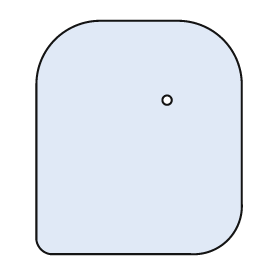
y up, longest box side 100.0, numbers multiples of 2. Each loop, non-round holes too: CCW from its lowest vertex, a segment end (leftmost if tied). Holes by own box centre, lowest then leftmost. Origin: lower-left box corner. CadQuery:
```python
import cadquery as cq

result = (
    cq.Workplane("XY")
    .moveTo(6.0, 0.0)
    .lineTo(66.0, 0.0)
    .threePointArc((82.0, 6.0), (88.0, 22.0))
    .lineTo(88.0, 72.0)
    .threePointArc((80.0, 92.0), (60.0, 100.0))
    .lineTo(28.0, 100.0)
    .threePointArc((8.0, 92.0), (0.0, 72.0))
    .lineTo(0.0, 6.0)
    .threePointArc((2.0, 2.0), (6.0, 0.0))
    .close()
    .moveTo(56.0, 66.0)
    .circle(2.0)
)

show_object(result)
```